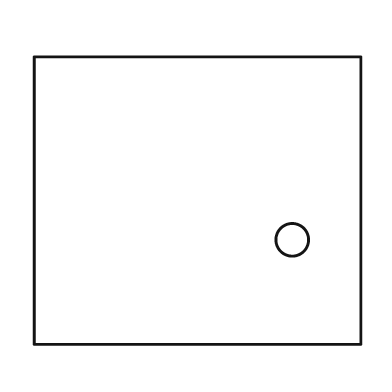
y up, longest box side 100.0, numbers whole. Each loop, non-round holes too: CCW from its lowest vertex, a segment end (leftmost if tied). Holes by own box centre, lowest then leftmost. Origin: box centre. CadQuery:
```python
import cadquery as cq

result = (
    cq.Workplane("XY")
    .moveTo(-50.0, -44.0)
    .lineTo(50.0, -44.0)
    .lineTo(50.0, 44.0)
    .lineTo(-50.0, 44.0)
    .close()
    .moveTo(29.0, -12.0)
    .circle(5.0)
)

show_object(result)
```